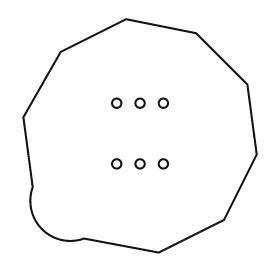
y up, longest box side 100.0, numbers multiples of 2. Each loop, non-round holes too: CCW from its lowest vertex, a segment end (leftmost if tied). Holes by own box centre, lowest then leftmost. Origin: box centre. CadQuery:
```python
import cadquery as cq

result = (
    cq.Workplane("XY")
    .moveTo(8.0, -50.0)
    .lineTo(36.0, -36.0)
    .lineTo(50.0, -8.0)
    .lineTo(46.0, 22.0)
    .lineTo(24.0, 44.0)
    .lineTo(-6.0, 50.0)
    .lineTo(-34.0, 36.0)
    .lineTo(-50.0, 8.0)
    .lineTo(-46.0, -22.0)
    .threePointArc((-42.0, -40.0), (-24.0, -44.0))
    .close()
    .moveTo(-10.0, -12.0)
    .circle(2.0)
    .moveTo(0.0, -12.0)
    .circle(2.0)
    .moveTo(10.0, -12.0)
    .circle(2.0)
    .moveTo(-10.0, 14.0)
    .circle(2.0)
    .moveTo(0.0, 14.0)
    .circle(2.0)
    .moveTo(10.0, 14.0)
    .circle(2.0)
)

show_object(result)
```